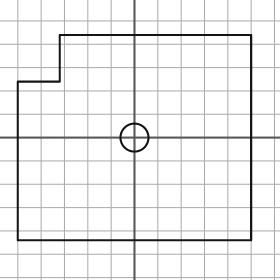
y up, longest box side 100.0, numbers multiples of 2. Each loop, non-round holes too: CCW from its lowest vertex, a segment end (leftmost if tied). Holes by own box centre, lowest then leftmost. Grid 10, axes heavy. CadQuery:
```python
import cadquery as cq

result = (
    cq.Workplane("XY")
    .moveTo(-50.0, -44.0)
    .lineTo(50.0, -44.0)
    .lineTo(50.0, 44.0)
    .lineTo(-32.0, 44.0)
    .lineTo(-32.0, 24.0)
    .lineTo(-50.0, 24.0)
    .close()
    .moveTo(0.0, 0.0)
    .circle(6.0)
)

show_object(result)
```